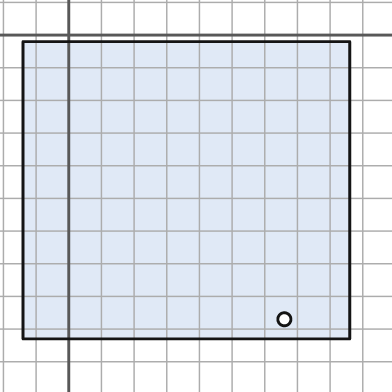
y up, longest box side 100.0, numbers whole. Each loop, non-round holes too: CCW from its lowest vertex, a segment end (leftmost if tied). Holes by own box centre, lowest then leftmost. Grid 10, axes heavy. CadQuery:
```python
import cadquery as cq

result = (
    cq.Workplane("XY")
    .moveTo(-14.0, -93.0)
    .lineTo(86.0, -93.0)
    .lineTo(86.0, -2.0)
    .lineTo(-14.0, -2.0)
    .close()
    .moveTo(66.0, -87.0)
    .circle(2.0)
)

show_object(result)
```